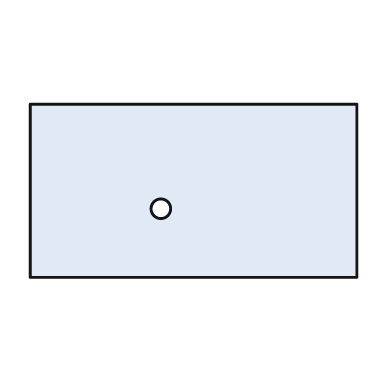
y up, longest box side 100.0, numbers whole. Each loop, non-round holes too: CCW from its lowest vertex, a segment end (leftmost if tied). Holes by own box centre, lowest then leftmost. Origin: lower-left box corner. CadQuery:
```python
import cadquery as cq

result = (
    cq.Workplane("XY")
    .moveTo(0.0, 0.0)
    .lineTo(100.0, 0.0)
    .lineTo(100.0, 53.0)
    .lineTo(0.0, 53.0)
    .close()
    .moveTo(40.0, 21.0)
    .circle(3.0)
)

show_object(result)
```